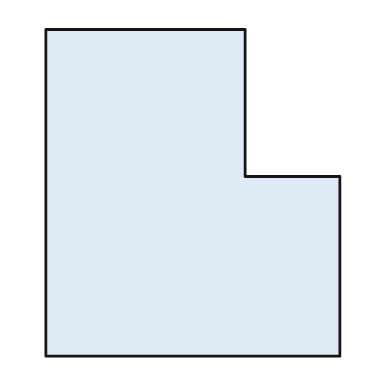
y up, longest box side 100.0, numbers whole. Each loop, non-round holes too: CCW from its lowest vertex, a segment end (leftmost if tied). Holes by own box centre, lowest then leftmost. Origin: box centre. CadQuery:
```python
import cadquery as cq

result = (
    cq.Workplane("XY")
    .moveTo(-45.0, -50.0)
    .lineTo(45.0, -50.0)
    .lineTo(45.0, 5.0)
    .lineTo(16.0, 5.0)
    .lineTo(16.0, 50.0)
    .lineTo(-45.0, 50.0)
    .close()
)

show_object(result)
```